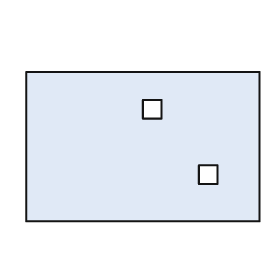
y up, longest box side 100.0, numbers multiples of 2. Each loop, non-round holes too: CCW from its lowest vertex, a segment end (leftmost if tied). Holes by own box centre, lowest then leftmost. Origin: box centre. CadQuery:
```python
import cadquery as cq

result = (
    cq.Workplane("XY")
    .moveTo(-50.0, -32.0)
    .lineTo(50.0, -32.0)
    .lineTo(50.0, 32.0)
    .lineTo(-50.0, 32.0)
    .close()
    .moveTo(24.0, -16.0)
    .lineTo(32.0, -16.0)
    .lineTo(32.0, -8.0)
    .lineTo(24.0, -8.0)
    .close()
    .moveTo(0.0, 12.0)
    .lineTo(8.0, 12.0)
    .lineTo(8.0, 20.0)
    .lineTo(0.0, 20.0)
    .close()
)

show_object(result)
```